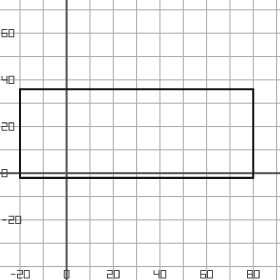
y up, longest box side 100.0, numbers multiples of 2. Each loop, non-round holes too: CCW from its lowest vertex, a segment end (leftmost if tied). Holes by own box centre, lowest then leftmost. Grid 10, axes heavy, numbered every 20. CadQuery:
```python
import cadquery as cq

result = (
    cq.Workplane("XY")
    .moveTo(-20.0, -2.0)
    .lineTo(80.0, -2.0)
    .lineTo(80.0, 36.0)
    .lineTo(-20.0, 36.0)
    .close()
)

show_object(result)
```